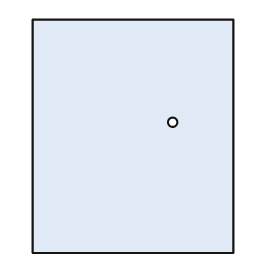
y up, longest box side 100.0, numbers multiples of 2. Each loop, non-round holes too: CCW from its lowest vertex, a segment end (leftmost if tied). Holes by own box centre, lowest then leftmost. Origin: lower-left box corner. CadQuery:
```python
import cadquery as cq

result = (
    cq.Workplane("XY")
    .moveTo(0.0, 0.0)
    .lineTo(86.0, 0.0)
    .lineTo(86.0, 100.0)
    .lineTo(0.0, 100.0)
    .close()
    .moveTo(60.0, 56.0)
    .circle(2.0)
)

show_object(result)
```